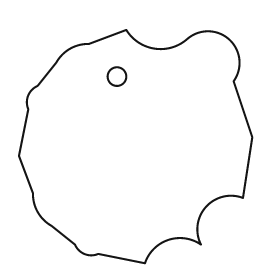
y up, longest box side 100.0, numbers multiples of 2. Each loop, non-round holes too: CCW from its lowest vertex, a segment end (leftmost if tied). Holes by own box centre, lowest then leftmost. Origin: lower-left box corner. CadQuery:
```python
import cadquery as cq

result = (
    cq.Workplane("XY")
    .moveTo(54.0, 0.0)
    .threePointArc((64.0, 10.0), (78.0, 8.0))
    .threePointArc((80.0, 24.0), (96.0, 28.0))
    .lineTo(100.0, 54.0)
    .lineTo(92.0, 78.0)
    .threePointArc((90.0, 96.0), (72.0, 96.0))
    .threePointArc((58.0, 92.0), (46.0, 100.0))
    .lineTo(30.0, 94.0)
    .threePointArc((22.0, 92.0), (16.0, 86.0))
    .lineTo(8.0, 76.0)
    .threePointArc((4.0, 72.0), (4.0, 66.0))
    .lineTo(0.0, 46.0)
    .lineTo(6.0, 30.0)
    .threePointArc((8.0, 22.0), (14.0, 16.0))
    .lineTo(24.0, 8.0)
    .threePointArc((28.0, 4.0), (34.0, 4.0))
    .close()
    .moveTo(42.0, 80.0)
    .circle(4.0)
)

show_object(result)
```